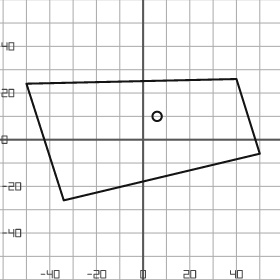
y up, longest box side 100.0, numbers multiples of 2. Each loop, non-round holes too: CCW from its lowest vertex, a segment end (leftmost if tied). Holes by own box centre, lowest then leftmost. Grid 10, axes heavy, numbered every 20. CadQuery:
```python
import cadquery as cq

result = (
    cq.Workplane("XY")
    .moveTo(-34.0, -26.0)
    .lineTo(50.0, -6.0)
    .lineTo(40.0, 26.0)
    .lineTo(-50.0, 24.0)
    .close()
    .moveTo(6.0, 10.0)
    .circle(2.0)
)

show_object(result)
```